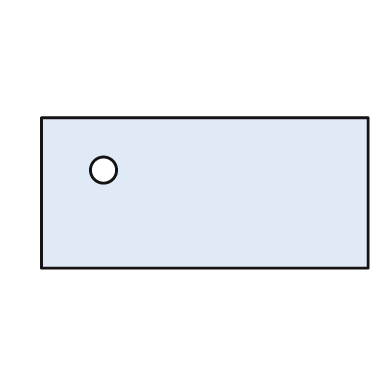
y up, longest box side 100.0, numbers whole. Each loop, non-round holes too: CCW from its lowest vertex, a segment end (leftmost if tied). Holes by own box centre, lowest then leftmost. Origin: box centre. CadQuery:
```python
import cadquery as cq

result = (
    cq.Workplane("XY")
    .moveTo(-50.0, -23.0)
    .lineTo(50.0, -23.0)
    .lineTo(50.0, 23.0)
    .lineTo(-50.0, 23.0)
    .close()
    .moveTo(-31.0, 7.0)
    .circle(4.0)
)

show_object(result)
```